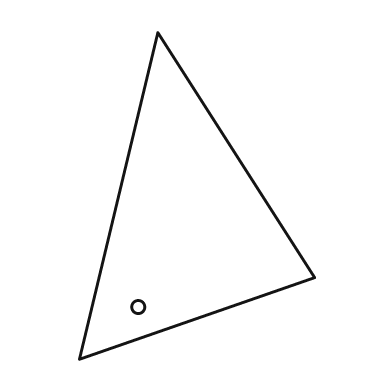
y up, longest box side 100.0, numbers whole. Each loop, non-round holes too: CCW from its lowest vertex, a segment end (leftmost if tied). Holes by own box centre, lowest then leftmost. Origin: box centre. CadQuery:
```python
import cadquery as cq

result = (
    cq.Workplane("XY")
    .moveTo(-36.0, -50.0)
    .lineTo(36.0, -25.0)
    .lineTo(-12.0, 50.0)
    .close()
    .moveTo(-18.0, -34.0)
    .circle(2.0)
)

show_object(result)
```